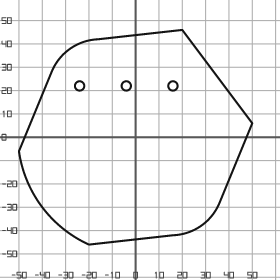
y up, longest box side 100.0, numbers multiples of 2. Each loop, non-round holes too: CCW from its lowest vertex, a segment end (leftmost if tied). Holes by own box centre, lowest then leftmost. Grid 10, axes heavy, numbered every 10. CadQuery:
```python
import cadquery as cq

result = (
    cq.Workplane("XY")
    .moveTo(-20.0, -46.0)
    .lineTo(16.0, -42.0)
    .threePointArc((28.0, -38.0), (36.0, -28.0))
    .lineTo(50.0, 6.0)
    .lineTo(20.0, 46.0)
    .lineTo(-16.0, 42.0)
    .threePointArc((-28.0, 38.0), (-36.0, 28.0))
    .lineTo(-50.0, -6.0)
    .threePointArc((-40.0, -30.0), (-20.0, -46.0))
    .close()
    .moveTo(-24.0, 22.0)
    .circle(2.0)
    .moveTo(-4.0, 22.0)
    .circle(2.0)
    .moveTo(16.0, 22.0)
    .circle(2.0)
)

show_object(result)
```